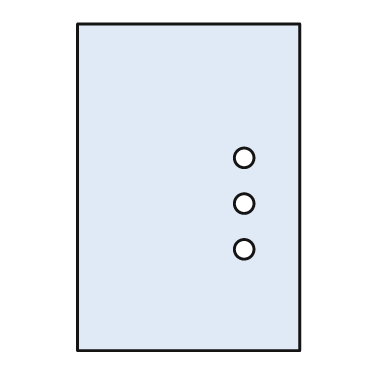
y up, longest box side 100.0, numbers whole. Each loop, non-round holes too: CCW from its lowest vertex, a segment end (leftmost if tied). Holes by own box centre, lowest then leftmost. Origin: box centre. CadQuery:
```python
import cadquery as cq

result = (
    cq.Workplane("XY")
    .moveTo(-34.0, -50.0)
    .lineTo(34.0, -50.0)
    .lineTo(34.0, 50.0)
    .lineTo(-34.0, 50.0)
    .close()
    .moveTo(17.0, -19.0)
    .circle(3.0)
    .moveTo(17.0, -5.0)
    .circle(3.0)
    .moveTo(17.0, 9.0)
    .circle(3.0)
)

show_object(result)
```